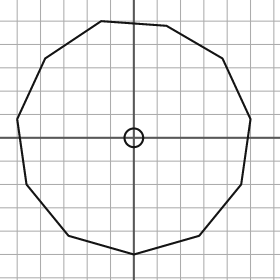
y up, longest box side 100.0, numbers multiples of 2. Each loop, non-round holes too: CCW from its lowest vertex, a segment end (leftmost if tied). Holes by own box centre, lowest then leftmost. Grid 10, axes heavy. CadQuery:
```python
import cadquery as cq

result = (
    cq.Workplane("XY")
    .moveTo(0.0, -50.0)
    .lineTo(28.0, -42.0)
    .lineTo(46.0, -20.0)
    .lineTo(50.0, 8.0)
    .lineTo(38.0, 34.0)
    .lineTo(14.0, 48.0)
    .lineTo(-14.0, 50.0)
    .lineTo(-38.0, 34.0)
    .lineTo(-50.0, 8.0)
    .lineTo(-46.0, -20.0)
    .lineTo(-28.0, -42.0)
    .close()
    .moveTo(0.0, 0.0)
    .circle(4.0)
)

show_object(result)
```